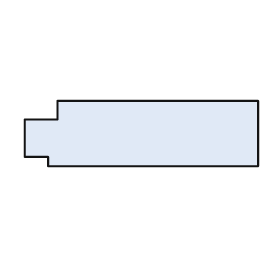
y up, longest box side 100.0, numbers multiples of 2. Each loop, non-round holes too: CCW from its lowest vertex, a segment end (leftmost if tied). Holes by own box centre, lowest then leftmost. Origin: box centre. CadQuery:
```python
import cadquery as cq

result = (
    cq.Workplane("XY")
    .moveTo(-40.0, -14.0)
    .lineTo(50.0, -14.0)
    .lineTo(50.0, 14.0)
    .lineTo(-36.0, 14.0)
    .lineTo(-36.0, 6.0)
    .lineTo(-50.0, 6.0)
    .lineTo(-50.0, -10.0)
    .lineTo(-40.0, -10.0)
    .close()
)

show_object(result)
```